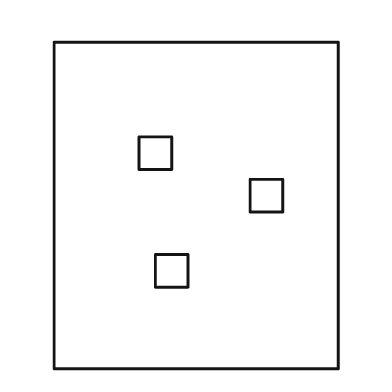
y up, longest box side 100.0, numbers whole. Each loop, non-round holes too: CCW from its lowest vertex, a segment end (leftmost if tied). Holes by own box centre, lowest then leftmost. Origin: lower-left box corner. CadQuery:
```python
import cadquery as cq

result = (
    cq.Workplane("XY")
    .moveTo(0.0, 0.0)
    .lineTo(87.0, 0.0)
    .lineTo(87.0, 100.0)
    .lineTo(0.0, 100.0)
    .close()
    .moveTo(31.0, 25.0)
    .lineTo(41.0, 25.0)
    .lineTo(41.0, 35.0)
    .lineTo(31.0, 35.0)
    .close()
    .moveTo(60.0, 48.0)
    .lineTo(70.0, 48.0)
    .lineTo(70.0, 58.0)
    .lineTo(60.0, 58.0)
    .close()
    .moveTo(26.0, 61.0)
    .lineTo(36.0, 61.0)
    .lineTo(36.0, 71.0)
    .lineTo(26.0, 71.0)
    .close()
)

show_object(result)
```